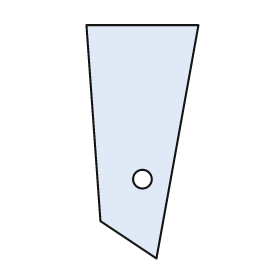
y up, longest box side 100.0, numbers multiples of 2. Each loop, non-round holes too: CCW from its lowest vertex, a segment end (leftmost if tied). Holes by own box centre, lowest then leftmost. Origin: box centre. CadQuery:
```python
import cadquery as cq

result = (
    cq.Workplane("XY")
    .moveTo(6.0, -50.0)
    .lineTo(24.0, 50.0)
    .lineTo(-24.0, 50.0)
    .lineTo(-18.0, -34.0)
    .close()
    .moveTo(0.0, -16.0)
    .circle(4.0)
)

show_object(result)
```